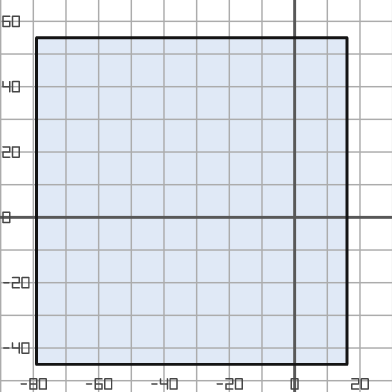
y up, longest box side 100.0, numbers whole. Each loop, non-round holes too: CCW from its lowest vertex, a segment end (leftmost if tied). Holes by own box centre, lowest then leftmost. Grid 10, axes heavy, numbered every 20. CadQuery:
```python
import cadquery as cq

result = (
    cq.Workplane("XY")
    .moveTo(-79.0, -45.0)
    .lineTo(16.0, -45.0)
    .lineTo(16.0, 55.0)
    .lineTo(-79.0, 55.0)
    .close()
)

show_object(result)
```